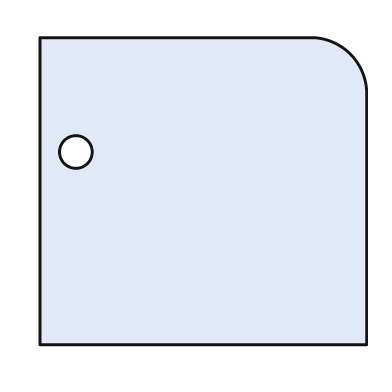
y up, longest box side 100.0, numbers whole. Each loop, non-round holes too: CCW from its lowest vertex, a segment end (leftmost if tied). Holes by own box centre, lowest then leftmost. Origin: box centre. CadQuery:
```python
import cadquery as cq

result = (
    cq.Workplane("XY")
    .moveTo(-50.0, -47.0)
    .lineTo(50.0, -47.0)
    .lineTo(50.0, 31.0)
    .threePointArc((45.0, 42.0), (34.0, 47.0))
    .lineTo(-50.0, 47.0)
    .close()
    .moveTo(-39.0, 12.0)
    .circle(5.0)
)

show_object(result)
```